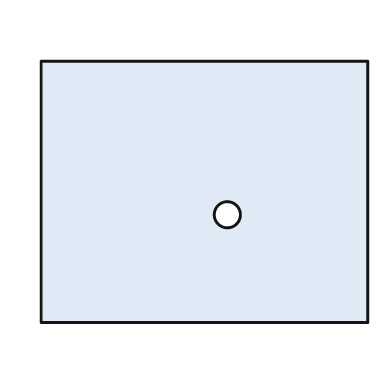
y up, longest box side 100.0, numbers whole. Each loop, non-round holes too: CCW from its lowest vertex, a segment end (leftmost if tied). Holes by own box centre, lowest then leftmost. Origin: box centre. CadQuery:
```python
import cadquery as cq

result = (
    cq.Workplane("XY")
    .moveTo(-50.0, -40.0)
    .lineTo(50.0, -40.0)
    .lineTo(50.0, 40.0)
    .lineTo(-50.0, 40.0)
    .close()
    .moveTo(7.0, -7.0)
    .circle(4.0)
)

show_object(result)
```